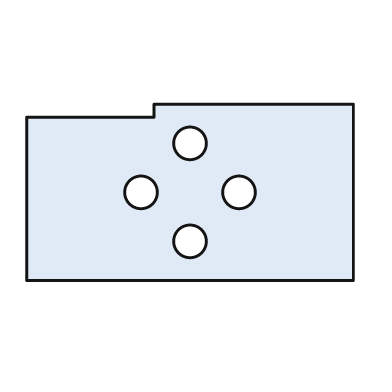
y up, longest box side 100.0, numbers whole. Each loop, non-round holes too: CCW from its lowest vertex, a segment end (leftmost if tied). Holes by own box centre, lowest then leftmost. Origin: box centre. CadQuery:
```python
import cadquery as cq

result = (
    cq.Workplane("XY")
    .moveTo(-50.0, -27.0)
    .lineTo(50.0, -27.0)
    .lineTo(50.0, 27.0)
    .lineTo(-11.0, 27.0)
    .lineTo(-11.0, 23.0)
    .lineTo(-50.0, 23.0)
    .close()
    .moveTo(0.0, -15.0)
    .circle(5.0)
    .moveTo(-15.0, 0.0)
    .circle(5.0)
    .moveTo(15.0, 0.0)
    .circle(5.0)
    .moveTo(0.0, 15.0)
    .circle(5.0)
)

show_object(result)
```